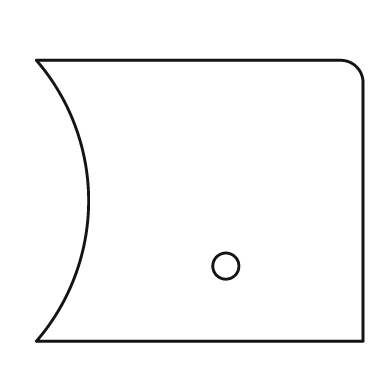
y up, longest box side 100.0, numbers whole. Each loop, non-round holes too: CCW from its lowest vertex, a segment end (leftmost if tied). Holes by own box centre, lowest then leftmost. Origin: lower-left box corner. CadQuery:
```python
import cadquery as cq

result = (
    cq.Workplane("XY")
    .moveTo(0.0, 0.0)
    .lineTo(100.0, 0.0)
    .lineTo(100.0, 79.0)
    .threePointArc((98.0, 84.0), (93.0, 86.0))
    .lineTo(0.0, 86.0)
    .threePointArc((16.0, 43.0), (0.0, 0.0))
    .close()
    .moveTo(58.0, 23.0)
    .circle(4.0)
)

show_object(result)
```